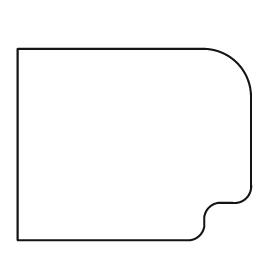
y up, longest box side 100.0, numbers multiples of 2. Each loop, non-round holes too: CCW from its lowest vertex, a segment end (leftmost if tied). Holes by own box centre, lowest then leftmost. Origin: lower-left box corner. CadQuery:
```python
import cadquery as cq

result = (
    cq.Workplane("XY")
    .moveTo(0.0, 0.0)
    .lineTo(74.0, 0.0)
    .threePointArc((78.0, 2.0), (80.0, 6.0))
    .lineTo(80.0, 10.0)
    .threePointArc((82.0, 14.0), (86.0, 16.0))
    .lineTo(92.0, 16.0)
    .threePointArc((98.0, 18.0), (100.0, 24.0))
    .lineTo(100.0, 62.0)
    .threePointArc((94.0, 76.0), (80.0, 82.0))
    .lineTo(0.0, 82.0)
    .close()
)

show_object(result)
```